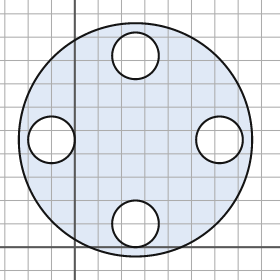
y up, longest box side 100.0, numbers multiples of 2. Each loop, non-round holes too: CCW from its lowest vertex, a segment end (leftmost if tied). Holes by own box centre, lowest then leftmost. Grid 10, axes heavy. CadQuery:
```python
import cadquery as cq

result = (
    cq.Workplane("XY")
    .moveTo(26.0, 46.0)
    .circle(50.0)
    .moveTo(26.0, 10.0)
    .circle(10.0)
    .moveTo(-10.0, 46.0)
    .circle(10.0)
    .moveTo(62.0, 46.0)
    .circle(10.0)
    .moveTo(26.0, 82.0)
    .circle(10.0)
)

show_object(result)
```